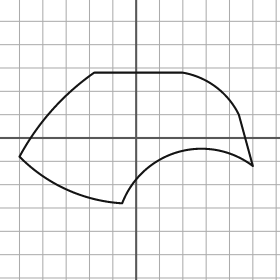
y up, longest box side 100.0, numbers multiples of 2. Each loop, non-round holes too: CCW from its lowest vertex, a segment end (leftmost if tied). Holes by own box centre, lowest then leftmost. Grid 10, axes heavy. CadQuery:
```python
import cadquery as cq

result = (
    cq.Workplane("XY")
    .moveTo(-6.0, -28.0)
    .threePointArc((18.0, -6.0), (50.0, -12.0))
    .lineTo(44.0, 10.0)
    .threePointArc((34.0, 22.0), (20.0, 28.0))
    .lineTo(-18.0, 28.0)
    .threePointArc((-36.0, 12.0), (-50.0, -8.0))
    .threePointArc((-30.0, -22.0), (-6.0, -28.0))
    .close()
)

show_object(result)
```